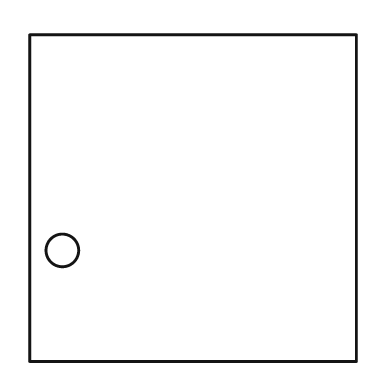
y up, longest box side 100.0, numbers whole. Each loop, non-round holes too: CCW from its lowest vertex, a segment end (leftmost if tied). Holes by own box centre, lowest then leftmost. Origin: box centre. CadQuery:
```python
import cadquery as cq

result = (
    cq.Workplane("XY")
    .moveTo(-50.0, -50.0)
    .lineTo(50.0, -50.0)
    .lineTo(50.0, 50.0)
    .lineTo(-50.0, 50.0)
    .close()
    .moveTo(-40.0, -16.0)
    .circle(5.0)
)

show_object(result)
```